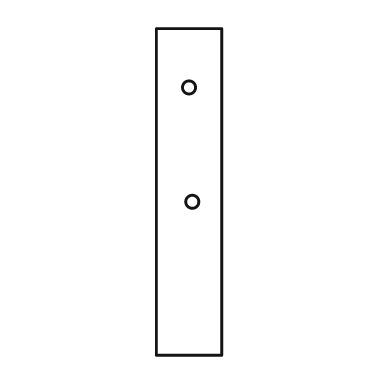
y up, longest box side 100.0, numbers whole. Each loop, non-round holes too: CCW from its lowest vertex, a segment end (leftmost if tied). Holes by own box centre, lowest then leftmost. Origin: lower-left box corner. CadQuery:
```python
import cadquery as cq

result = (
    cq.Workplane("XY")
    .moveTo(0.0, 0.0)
    .lineTo(20.0, 0.0)
    .lineTo(20.0, 100.0)
    .lineTo(0.0, 100.0)
    .close()
    .moveTo(11.0, 47.0)
    .circle(2.0)
    .moveTo(10.0, 82.0)
    .circle(2.0)
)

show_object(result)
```